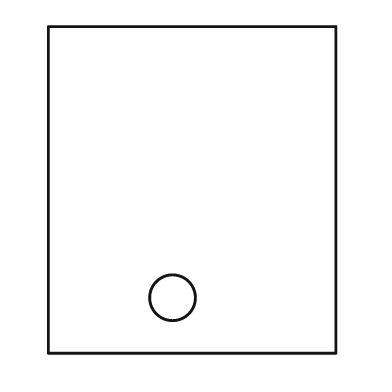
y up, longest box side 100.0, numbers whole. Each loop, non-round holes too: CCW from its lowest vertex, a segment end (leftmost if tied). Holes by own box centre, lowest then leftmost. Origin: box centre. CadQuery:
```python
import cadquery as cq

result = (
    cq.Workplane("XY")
    .moveTo(-44.0, -50.0)
    .lineTo(44.0, -50.0)
    .lineTo(44.0, 50.0)
    .lineTo(-44.0, 50.0)
    .close()
    .moveTo(-6.0, -33.0)
    .circle(7.0)
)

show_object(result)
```